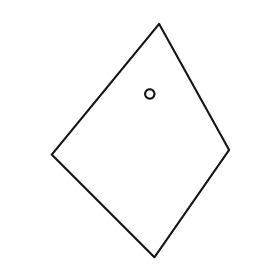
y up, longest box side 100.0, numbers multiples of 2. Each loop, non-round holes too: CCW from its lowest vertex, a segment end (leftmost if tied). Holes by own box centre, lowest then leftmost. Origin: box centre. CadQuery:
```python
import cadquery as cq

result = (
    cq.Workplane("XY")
    .moveTo(6.0, -50.0)
    .lineTo(38.0, -4.0)
    .lineTo(8.0, 50.0)
    .lineTo(-38.0, -6.0)
    .close()
    .moveTo(4.0, 20.0)
    .circle(2.0)
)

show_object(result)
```